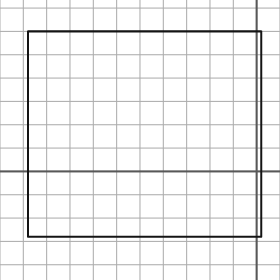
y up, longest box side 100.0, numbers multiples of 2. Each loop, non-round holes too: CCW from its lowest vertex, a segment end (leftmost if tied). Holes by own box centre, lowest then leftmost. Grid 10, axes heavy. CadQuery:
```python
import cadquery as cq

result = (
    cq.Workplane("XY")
    .moveTo(-98.0, -28.0)
    .lineTo(2.0, -28.0)
    .lineTo(2.0, 60.0)
    .lineTo(-98.0, 60.0)
    .close()
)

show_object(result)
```